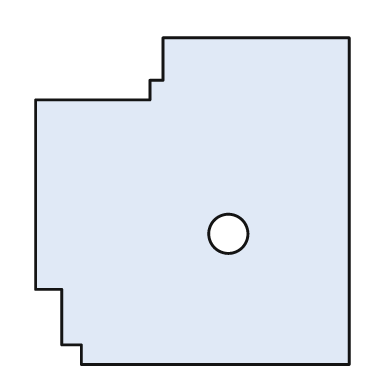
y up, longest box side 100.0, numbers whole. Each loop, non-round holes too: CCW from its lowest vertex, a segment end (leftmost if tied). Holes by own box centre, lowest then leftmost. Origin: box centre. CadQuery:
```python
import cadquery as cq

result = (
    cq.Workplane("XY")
    .moveTo(-34.0, -50.0)
    .lineTo(48.0, -50.0)
    .lineTo(48.0, 50.0)
    .lineTo(-9.0, 50.0)
    .lineTo(-9.0, 37.0)
    .lineTo(-13.0, 37.0)
    .lineTo(-13.0, 31.0)
    .lineTo(-48.0, 31.0)
    .lineTo(-48.0, -27.0)
    .lineTo(-40.0, -27.0)
    .lineTo(-40.0, -44.0)
    .lineTo(-34.0, -44.0)
    .close()
    .moveTo(11.0, -10.0)
    .circle(6.0)
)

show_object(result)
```